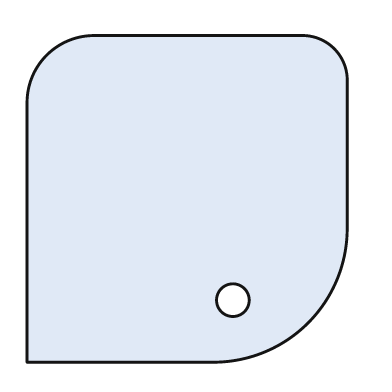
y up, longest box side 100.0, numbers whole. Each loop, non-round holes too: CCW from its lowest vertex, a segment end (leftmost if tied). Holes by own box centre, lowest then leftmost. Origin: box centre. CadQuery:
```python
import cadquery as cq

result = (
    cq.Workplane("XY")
    .moveTo(-49.0, -50.0)
    .lineTo(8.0, -50.0)
    .threePointArc((37.0, -38.0), (49.0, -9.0))
    .lineTo(49.0, 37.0)
    .threePointArc((45.0, 46.0), (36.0, 50.0))
    .lineTo(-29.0, 50.0)
    .threePointArc((-43.0, 44.0), (-49.0, 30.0))
    .close()
    .moveTo(14.0, -31.0)
    .circle(5.0)
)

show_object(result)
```